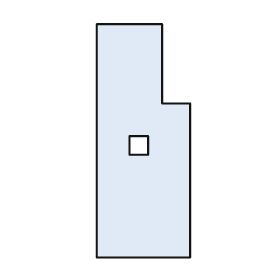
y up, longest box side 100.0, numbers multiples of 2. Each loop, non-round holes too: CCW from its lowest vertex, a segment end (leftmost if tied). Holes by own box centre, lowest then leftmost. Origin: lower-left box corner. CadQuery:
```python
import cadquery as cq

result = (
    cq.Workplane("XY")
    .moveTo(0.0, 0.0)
    .lineTo(40.0, 0.0)
    .lineTo(40.0, 66.0)
    .lineTo(28.0, 66.0)
    .lineTo(28.0, 100.0)
    .lineTo(0.0, 100.0)
    .close()
    .moveTo(14.0, 44.0)
    .lineTo(22.0, 44.0)
    .lineTo(22.0, 52.0)
    .lineTo(14.0, 52.0)
    .close()
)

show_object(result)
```